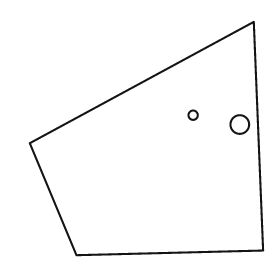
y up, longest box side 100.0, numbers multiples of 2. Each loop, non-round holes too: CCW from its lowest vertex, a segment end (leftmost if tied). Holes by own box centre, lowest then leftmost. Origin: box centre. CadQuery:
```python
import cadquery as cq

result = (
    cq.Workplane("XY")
    .moveTo(-30.0, -50.0)
    .lineTo(50.0, -48.0)
    .lineTo(46.0, 50.0)
    .lineTo(-50.0, -2.0)
    .close()
    .moveTo(40.0, 6.0)
    .circle(4.0)
    .moveTo(20.0, 10.0)
    .circle(2.0)
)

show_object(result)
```